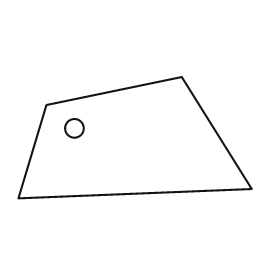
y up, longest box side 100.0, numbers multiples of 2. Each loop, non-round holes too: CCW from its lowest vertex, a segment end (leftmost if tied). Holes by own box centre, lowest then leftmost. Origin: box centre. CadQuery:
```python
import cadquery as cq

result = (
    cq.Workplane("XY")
    .moveTo(-50.0, -26.0)
    .lineTo(50.0, -22.0)
    .lineTo(20.0, 26.0)
    .lineTo(-38.0, 14.0)
    .close()
    .moveTo(-26.0, 4.0)
    .circle(4.0)
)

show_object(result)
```